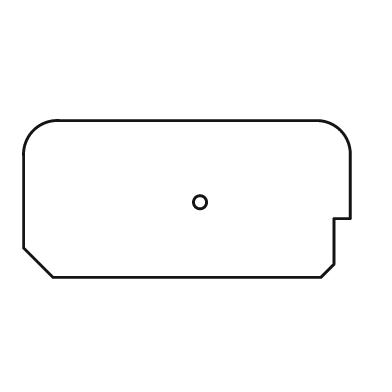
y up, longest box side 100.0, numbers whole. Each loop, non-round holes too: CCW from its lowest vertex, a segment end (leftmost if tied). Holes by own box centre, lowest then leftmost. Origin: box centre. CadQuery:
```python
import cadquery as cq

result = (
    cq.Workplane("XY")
    .moveTo(-41.0, -24.0)
    .lineTo(41.0, -24.0)
    .lineTo(45.0, -20.0)
    .lineTo(45.0, -6.0)
    .lineTo(50.0, -6.0)
    .lineTo(50.0, 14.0)
    .threePointArc((47.0, 21.0), (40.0, 24.0))
    .lineTo(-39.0, 24.0)
    .threePointArc((-47.0, 21.0), (-50.0, 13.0))
    .lineTo(-50.0, -15.0)
    .close()
    .moveTo(4.0, -1.0)
    .circle(2.0)
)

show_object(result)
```